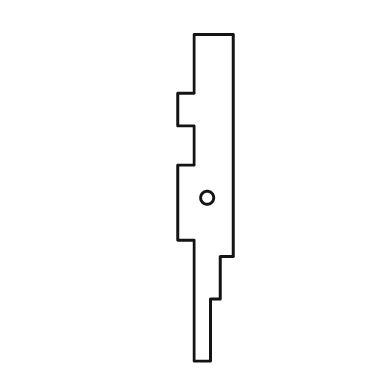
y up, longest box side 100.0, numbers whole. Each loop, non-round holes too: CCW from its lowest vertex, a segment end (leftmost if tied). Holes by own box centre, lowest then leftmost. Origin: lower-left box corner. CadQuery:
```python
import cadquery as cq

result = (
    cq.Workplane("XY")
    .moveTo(5.0, 0.0)
    .lineTo(10.0, 0.0)
    .lineTo(10.0, 19.0)
    .lineTo(13.0, 19.0)
    .lineTo(13.0, 32.0)
    .lineTo(17.0, 32.0)
    .lineTo(17.0, 100.0)
    .lineTo(5.0, 100.0)
    .lineTo(5.0, 82.0)
    .lineTo(0.0, 82.0)
    .lineTo(0.0, 72.0)
    .lineTo(5.0, 72.0)
    .lineTo(5.0, 60.0)
    .lineTo(0.0, 60.0)
    .lineTo(0.0, 37.0)
    .lineTo(5.0, 37.0)
    .close()
    .moveTo(9.0, 50.0)
    .circle(2.0)
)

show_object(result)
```